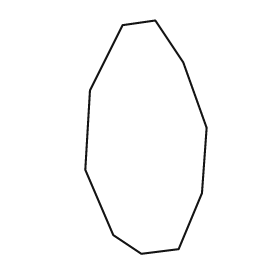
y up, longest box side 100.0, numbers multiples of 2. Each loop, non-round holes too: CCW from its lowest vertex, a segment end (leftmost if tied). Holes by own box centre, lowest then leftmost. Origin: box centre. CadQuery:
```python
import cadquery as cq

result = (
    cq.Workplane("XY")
    .moveTo(-2.0, -50.0)
    .lineTo(14.0, -48.0)
    .lineTo(24.0, -24.0)
    .lineTo(26.0, 4.0)
    .lineTo(16.0, 32.0)
    .lineTo(4.0, 50.0)
    .lineTo(-10.0, 48.0)
    .lineTo(-24.0, 20.0)
    .lineTo(-26.0, -14.0)
    .lineTo(-14.0, -42.0)
    .close()
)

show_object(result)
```